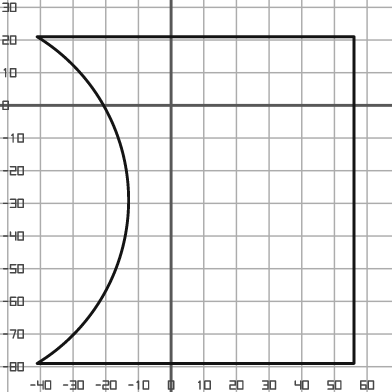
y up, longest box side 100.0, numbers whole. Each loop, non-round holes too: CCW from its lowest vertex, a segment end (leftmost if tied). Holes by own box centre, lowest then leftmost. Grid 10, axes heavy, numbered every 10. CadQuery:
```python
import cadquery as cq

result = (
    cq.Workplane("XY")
    .moveTo(-41.0, -79.0)
    .lineTo(56.0, -79.0)
    .lineTo(56.0, 21.0)
    .lineTo(-41.0, 21.0)
    .threePointArc((-13.0, -29.0), (-41.0, -79.0))
    .close()
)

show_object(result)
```